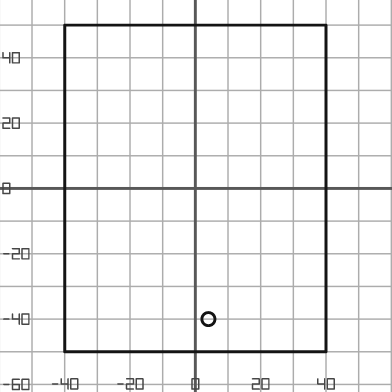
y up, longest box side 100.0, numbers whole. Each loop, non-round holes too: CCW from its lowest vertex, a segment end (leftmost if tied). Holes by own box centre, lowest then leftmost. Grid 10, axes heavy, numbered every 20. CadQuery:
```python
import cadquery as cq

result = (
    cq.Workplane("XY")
    .moveTo(-40.0, -50.0)
    .lineTo(40.0, -50.0)
    .lineTo(40.0, 50.0)
    .lineTo(-40.0, 50.0)
    .close()
    .moveTo(4.0, -40.0)
    .circle(2.0)
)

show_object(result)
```